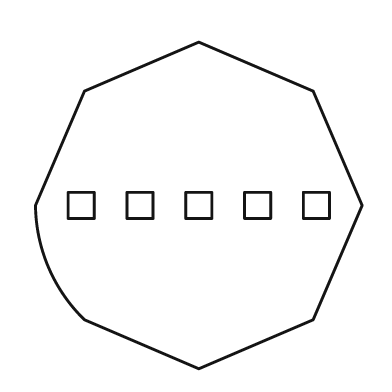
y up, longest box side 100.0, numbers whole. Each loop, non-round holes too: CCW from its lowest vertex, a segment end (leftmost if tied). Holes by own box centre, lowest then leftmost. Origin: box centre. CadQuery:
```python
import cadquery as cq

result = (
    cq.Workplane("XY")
    .moveTo(0.0, -50.0)
    .lineTo(35.0, -35.0)
    .lineTo(50.0, 0.0)
    .lineTo(35.0, 35.0)
    .lineTo(0.0, 50.0)
    .lineTo(-35.0, 35.0)
    .lineTo(-50.0, 0.0)
    .threePointArc((-46.0, -19.0), (-35.0, -35.0))
    .close()
    .moveTo(-40.0, -4.0)
    .lineTo(-32.0, -4.0)
    .lineTo(-32.0, 4.0)
    .lineTo(-40.0, 4.0)
    .close()
    .moveTo(-22.0, -4.0)
    .lineTo(-14.0, -4.0)
    .lineTo(-14.0, 4.0)
    .lineTo(-22.0, 4.0)
    .close()
    .moveTo(-4.0, -4.0)
    .lineTo(4.0, -4.0)
    .lineTo(4.0, 4.0)
    .lineTo(-4.0, 4.0)
    .close()
    .moveTo(14.0, -4.0)
    .lineTo(22.0, -4.0)
    .lineTo(22.0, 4.0)
    .lineTo(14.0, 4.0)
    .close()
    .moveTo(32.0, -4.0)
    .lineTo(40.0, -4.0)
    .lineTo(40.0, 4.0)
    .lineTo(32.0, 4.0)
    .close()
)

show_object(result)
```